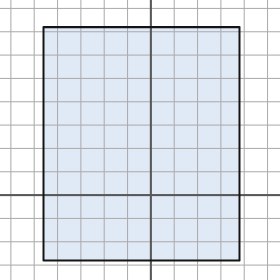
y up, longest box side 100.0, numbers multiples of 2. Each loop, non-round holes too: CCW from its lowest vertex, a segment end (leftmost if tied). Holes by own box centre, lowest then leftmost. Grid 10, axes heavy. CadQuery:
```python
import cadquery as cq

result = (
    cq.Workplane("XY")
    .moveTo(-46.0, -28.0)
    .lineTo(38.0, -28.0)
    .lineTo(38.0, 72.0)
    .lineTo(-46.0, 72.0)
    .close()
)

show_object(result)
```